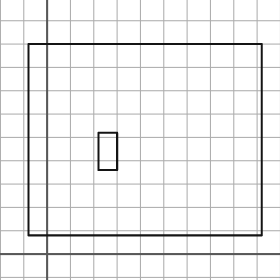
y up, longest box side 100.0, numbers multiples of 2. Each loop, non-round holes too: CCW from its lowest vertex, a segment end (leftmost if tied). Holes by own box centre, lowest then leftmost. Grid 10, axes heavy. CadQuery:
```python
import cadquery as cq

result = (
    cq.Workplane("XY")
    .moveTo(-8.0, 8.0)
    .lineTo(92.0, 8.0)
    .lineTo(92.0, 90.0)
    .lineTo(-8.0, 90.0)
    .close()
    .moveTo(22.0, 36.0)
    .lineTo(30.0, 36.0)
    .lineTo(30.0, 52.0)
    .lineTo(22.0, 52.0)
    .close()
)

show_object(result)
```